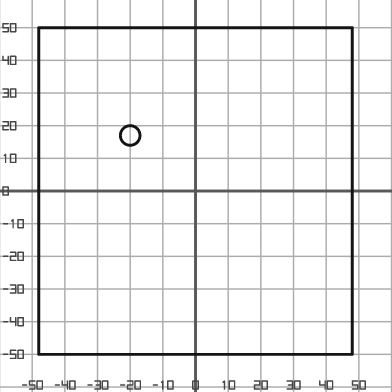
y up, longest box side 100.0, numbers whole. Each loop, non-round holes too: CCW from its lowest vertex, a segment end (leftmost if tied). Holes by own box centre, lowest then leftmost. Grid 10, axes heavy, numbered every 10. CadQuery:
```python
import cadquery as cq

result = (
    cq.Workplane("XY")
    .moveTo(-48.0, -50.0)
    .lineTo(48.0, -50.0)
    .lineTo(48.0, 50.0)
    .lineTo(-48.0, 50.0)
    .close()
    .moveTo(-20.0, 17.0)
    .circle(3.0)
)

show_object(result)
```